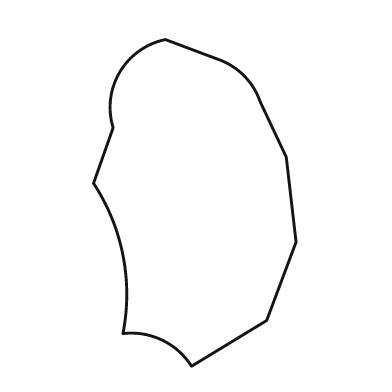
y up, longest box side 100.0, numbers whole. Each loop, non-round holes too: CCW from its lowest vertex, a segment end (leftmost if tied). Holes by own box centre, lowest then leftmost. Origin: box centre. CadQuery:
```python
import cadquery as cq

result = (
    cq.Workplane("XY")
    .moveTo(-1.0, -50.0)
    .lineTo(22.0, -36.0)
    .lineTo(31.0, -12.0)
    .lineTo(28.0, 14.0)
    .lineTo(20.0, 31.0)
    .threePointArc((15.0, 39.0), (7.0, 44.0))
    .lineTo(-9.0, 50.0)
    .threePointArc((-23.0, 40.0), (-25.0, 23.0))
    .lineTo(-31.0, 6.0)
    .threePointArc((-22.0, -16.0), (-22.0, -40.0))
    .threePointArc((-10.0, -42.0), (-1.0, -50.0))
    .close()
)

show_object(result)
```